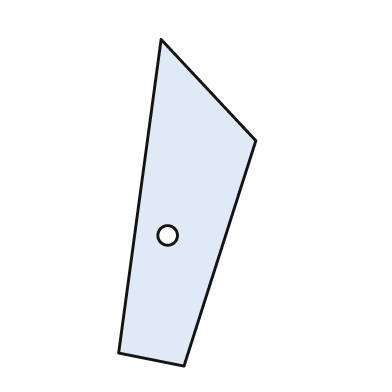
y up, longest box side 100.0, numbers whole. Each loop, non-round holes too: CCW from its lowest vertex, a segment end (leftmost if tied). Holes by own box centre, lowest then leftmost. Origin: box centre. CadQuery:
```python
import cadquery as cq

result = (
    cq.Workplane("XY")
    .moveTo(-1.0, -50.0)
    .lineTo(21.0, 19.0)
    .lineTo(-8.0, 50.0)
    .lineTo(-21.0, -46.0)
    .close()
    .moveTo(-6.0, -10.0)
    .circle(3.0)
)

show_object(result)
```